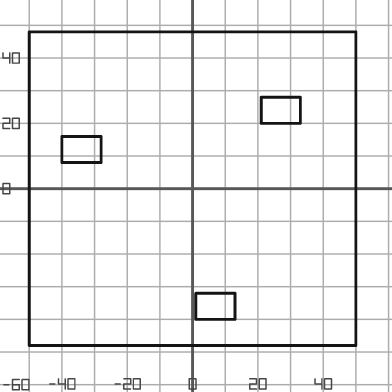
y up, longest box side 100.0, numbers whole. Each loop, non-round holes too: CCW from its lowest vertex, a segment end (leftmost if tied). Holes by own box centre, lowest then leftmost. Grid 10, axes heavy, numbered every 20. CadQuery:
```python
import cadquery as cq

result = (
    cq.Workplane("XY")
    .moveTo(-50.0, -48.0)
    .lineTo(50.0, -48.0)
    .lineTo(50.0, 48.0)
    .lineTo(-50.0, 48.0)
    .close()
    .moveTo(1.0, -40.0)
    .lineTo(13.0, -40.0)
    .lineTo(13.0, -32.0)
    .lineTo(1.0, -32.0)
    .close()
    .moveTo(-40.0, 8.0)
    .lineTo(-28.0, 8.0)
    .lineTo(-28.0, 16.0)
    .lineTo(-40.0, 16.0)
    .close()
    .moveTo(21.0, 20.0)
    .lineTo(33.0, 20.0)
    .lineTo(33.0, 28.0)
    .lineTo(21.0, 28.0)
    .close()
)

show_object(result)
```